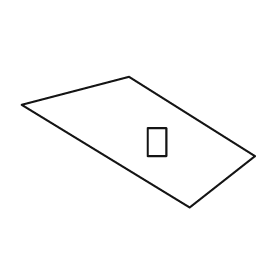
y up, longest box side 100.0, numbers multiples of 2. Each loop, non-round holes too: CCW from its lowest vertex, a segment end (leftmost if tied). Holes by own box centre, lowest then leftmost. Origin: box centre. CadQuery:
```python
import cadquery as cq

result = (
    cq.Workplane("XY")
    .moveTo(22.0, -28.0)
    .lineTo(50.0, -6.0)
    .lineTo(-4.0, 28.0)
    .lineTo(-50.0, 16.0)
    .close()
    .moveTo(4.0, -6.0)
    .lineTo(12.0, -6.0)
    .lineTo(12.0, 6.0)
    .lineTo(4.0, 6.0)
    .close()
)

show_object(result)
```